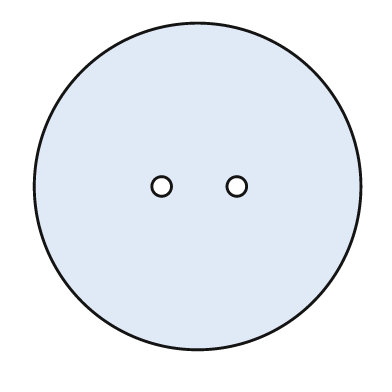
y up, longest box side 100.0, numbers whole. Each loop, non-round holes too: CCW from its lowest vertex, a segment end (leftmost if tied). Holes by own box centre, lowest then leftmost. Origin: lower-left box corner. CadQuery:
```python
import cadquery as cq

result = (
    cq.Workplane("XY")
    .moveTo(50.0, 50.0)
    .circle(50.0)
    .moveTo(39.0, 50.0)
    .circle(3.0)
    .moveTo(62.0, 50.0)
    .circle(3.0)
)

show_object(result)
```